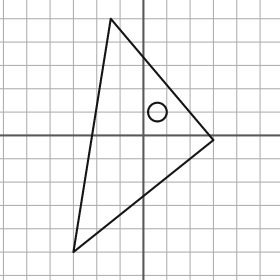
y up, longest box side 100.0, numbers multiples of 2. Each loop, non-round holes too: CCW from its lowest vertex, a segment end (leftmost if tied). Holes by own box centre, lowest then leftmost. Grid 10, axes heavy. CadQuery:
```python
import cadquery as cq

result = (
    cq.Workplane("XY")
    .moveTo(-30.0, -50.0)
    .lineTo(30.0, -2.0)
    .lineTo(-14.0, 50.0)
    .close()
    .moveTo(6.0, 10.0)
    .circle(4.0)
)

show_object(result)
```